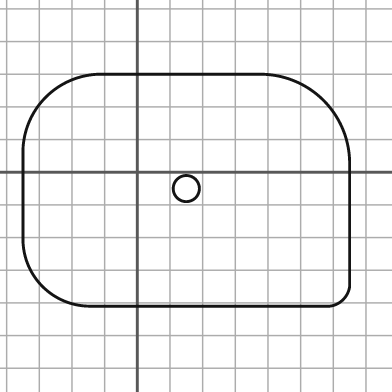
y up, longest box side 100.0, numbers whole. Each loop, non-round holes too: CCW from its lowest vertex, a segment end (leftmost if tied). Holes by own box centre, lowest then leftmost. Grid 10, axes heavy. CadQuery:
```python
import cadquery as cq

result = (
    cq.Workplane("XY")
    .moveTo(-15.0, -41.0)
    .lineTo(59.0, -41.0)
    .threePointArc((63.0, -39.0), (65.0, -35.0))
    .lineTo(65.0, 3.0)
    .threePointArc((57.0, 22.0), (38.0, 30.0))
    .lineTo(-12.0, 30.0)
    .threePointArc((-28.0, 23.0), (-35.0, 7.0))
    .lineTo(-35.0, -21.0)
    .threePointArc((-29.0, -35.0), (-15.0, -41.0))
    .close()
    .moveTo(15.0, -5.0)
    .circle(4.0)
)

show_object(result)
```